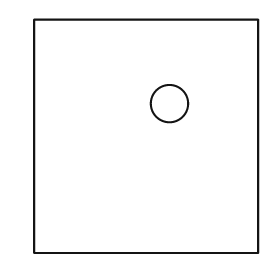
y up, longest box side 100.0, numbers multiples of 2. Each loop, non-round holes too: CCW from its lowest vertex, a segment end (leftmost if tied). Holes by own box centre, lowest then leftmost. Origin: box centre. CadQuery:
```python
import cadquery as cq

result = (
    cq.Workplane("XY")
    .moveTo(-48.0, -50.0)
    .lineTo(48.0, -50.0)
    .lineTo(48.0, 50.0)
    .lineTo(-48.0, 50.0)
    .close()
    .moveTo(10.0, 14.0)
    .circle(8.0)
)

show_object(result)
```